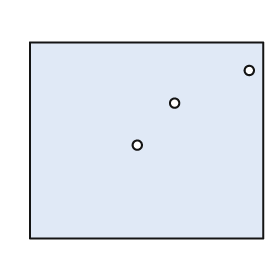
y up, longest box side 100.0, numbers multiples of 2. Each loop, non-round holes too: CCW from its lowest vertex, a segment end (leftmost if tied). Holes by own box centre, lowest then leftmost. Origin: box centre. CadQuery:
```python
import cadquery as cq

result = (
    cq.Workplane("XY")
    .moveTo(-50.0, -42.0)
    .lineTo(50.0, -42.0)
    .lineTo(50.0, 42.0)
    .lineTo(-50.0, 42.0)
    .close()
    .moveTo(-4.0, -2.0)
    .circle(2.0)
    .moveTo(12.0, 16.0)
    .circle(2.0)
    .moveTo(44.0, 30.0)
    .circle(2.0)
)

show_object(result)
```